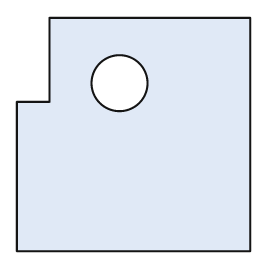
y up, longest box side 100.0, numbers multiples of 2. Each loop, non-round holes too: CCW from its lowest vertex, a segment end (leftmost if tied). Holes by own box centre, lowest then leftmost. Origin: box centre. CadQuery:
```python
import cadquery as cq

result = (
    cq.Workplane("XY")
    .moveTo(-50.0, -50.0)
    .lineTo(50.0, -50.0)
    .lineTo(50.0, 50.0)
    .lineTo(-36.0, 50.0)
    .lineTo(-36.0, 14.0)
    .lineTo(-50.0, 14.0)
    .close()
    .moveTo(-6.0, 22.0)
    .circle(12.0)
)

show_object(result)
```